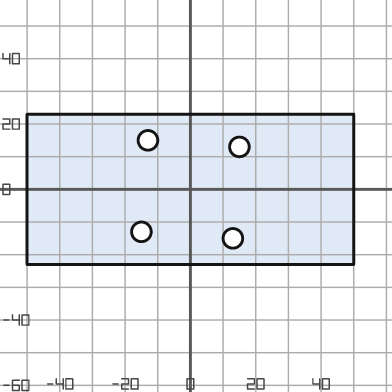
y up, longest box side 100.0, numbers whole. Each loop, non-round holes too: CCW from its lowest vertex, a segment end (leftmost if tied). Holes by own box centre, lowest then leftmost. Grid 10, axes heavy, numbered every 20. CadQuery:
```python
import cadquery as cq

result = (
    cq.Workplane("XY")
    .moveTo(-50.0, -23.0)
    .lineTo(50.0, -23.0)
    .lineTo(50.0, 23.0)
    .lineTo(-50.0, 23.0)
    .close()
    .moveTo(13.0, -15.0)
    .circle(3.0)
    .moveTo(-15.0, -13.0)
    .circle(3.0)
    .moveTo(15.0, 13.0)
    .circle(3.0)
    .moveTo(-13.0, 15.0)
    .circle(3.0)
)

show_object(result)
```